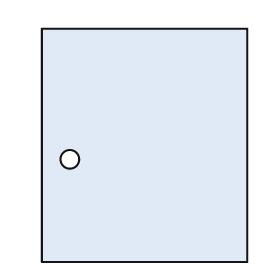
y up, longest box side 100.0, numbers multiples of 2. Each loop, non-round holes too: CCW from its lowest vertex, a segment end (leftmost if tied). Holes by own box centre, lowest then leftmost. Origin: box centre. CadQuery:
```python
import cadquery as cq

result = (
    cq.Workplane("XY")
    .moveTo(-44.0, -50.0)
    .lineTo(44.0, -50.0)
    .lineTo(44.0, 50.0)
    .lineTo(-44.0, 50.0)
    .close()
    .moveTo(-32.0, -6.0)
    .circle(4.0)
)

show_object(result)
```